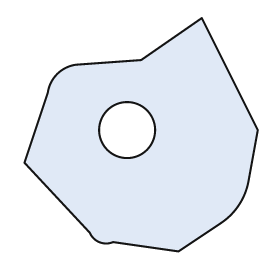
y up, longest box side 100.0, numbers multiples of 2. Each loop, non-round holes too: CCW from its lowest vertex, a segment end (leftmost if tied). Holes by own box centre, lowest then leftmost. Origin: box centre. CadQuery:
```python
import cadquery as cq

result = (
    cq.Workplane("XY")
    .moveTo(16.0, -50.0)
    .lineTo(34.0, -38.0)
    .threePointArc((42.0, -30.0), (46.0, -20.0))
    .lineTo(50.0, 2.0)
    .lineTo(26.0, 50.0)
    .lineTo(0.0, 32.0)
    .lineTo(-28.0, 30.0)
    .threePointArc((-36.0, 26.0), (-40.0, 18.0))
    .lineTo(-50.0, -12.0)
    .lineTo(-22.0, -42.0)
    .threePointArc((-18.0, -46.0), (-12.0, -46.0))
    .close()
    .moveTo(-6.0, 2.0)
    .circle(12.0)
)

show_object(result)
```